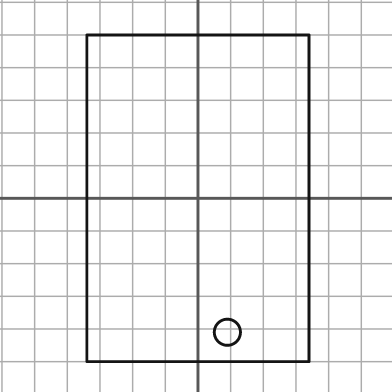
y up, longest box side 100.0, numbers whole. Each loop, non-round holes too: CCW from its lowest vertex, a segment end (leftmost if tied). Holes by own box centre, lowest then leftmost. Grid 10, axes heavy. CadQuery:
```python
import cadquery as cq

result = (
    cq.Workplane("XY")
    .moveTo(-34.0, -50.0)
    .lineTo(34.0, -50.0)
    .lineTo(34.0, 50.0)
    .lineTo(-34.0, 50.0)
    .close()
    .moveTo(9.0, -41.0)
    .circle(4.0)
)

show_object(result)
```